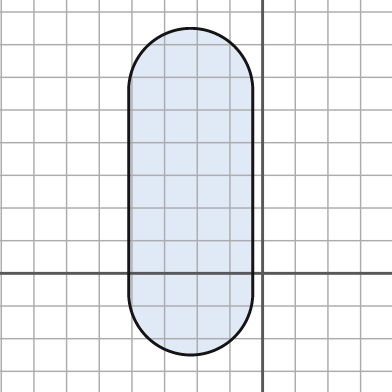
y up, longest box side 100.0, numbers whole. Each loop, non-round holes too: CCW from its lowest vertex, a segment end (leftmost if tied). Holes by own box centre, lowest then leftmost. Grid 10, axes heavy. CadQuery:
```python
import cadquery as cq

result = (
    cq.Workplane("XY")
    .moveTo(-41.0, -6.0)
    .threePointArc((-22.0, -25.0), (-3.0, -6.0))
    .lineTo(-3.0, 56.0)
    .threePointArc((-22.0, 75.0), (-41.0, 56.0))
    .close()
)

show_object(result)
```